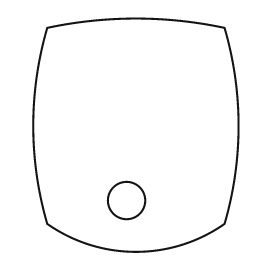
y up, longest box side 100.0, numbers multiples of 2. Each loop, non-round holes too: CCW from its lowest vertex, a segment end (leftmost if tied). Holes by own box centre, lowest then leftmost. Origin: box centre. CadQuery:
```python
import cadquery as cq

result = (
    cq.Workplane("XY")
    .moveTo(-38.0, -38.0)
    .threePointArc((0.0, -50.0), (38.0, -38.0))
    .threePointArc((44.0, 4.0), (38.0, 46.0))
    .threePointArc((0.0, 50.0), (-38.0, 46.0))
    .threePointArc((-44.0, 4.0), (-38.0, -38.0))
    .close()
    .moveTo(-4.0, -28.0)
    .circle(8.0)
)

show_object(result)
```